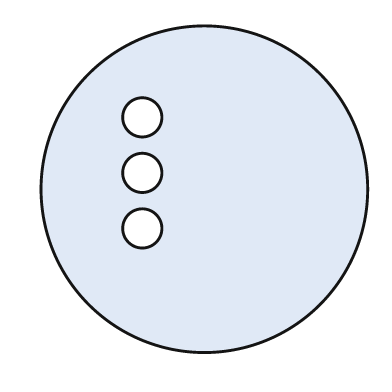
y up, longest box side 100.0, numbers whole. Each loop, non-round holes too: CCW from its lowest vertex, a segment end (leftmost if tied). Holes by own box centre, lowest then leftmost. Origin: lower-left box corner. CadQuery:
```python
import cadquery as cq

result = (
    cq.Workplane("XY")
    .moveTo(50.0, 50.0)
    .circle(50.0)
    .moveTo(31.0, 38.0)
    .circle(6.0)
    .moveTo(31.0, 55.0)
    .circle(6.0)
    .moveTo(31.0, 72.0)
    .circle(6.0)
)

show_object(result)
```